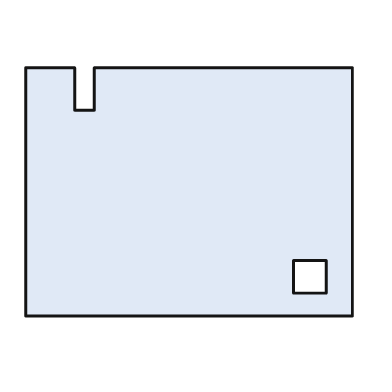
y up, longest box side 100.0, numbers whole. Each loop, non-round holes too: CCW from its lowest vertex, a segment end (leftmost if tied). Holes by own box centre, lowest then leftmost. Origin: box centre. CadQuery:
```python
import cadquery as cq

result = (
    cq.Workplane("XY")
    .moveTo(-50.0, -38.0)
    .lineTo(50.0, -38.0)
    .lineTo(50.0, 38.0)
    .lineTo(-29.0, 38.0)
    .lineTo(-29.0, 25.0)
    .lineTo(-35.0, 25.0)
    .lineTo(-35.0, 38.0)
    .lineTo(-50.0, 38.0)
    .close()
    .moveTo(32.0, -31.0)
    .lineTo(42.0, -31.0)
    .lineTo(42.0, -21.0)
    .lineTo(32.0, -21.0)
    .close()
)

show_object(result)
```